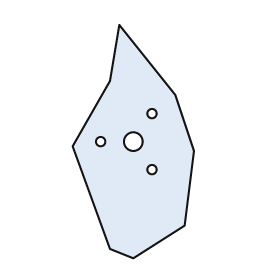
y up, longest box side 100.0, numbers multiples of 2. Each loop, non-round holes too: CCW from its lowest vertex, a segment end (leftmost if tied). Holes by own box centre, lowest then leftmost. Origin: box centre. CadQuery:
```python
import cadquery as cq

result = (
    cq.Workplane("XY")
    .moveTo(0.0, -50.0)
    .lineTo(22.0, -36.0)
    .lineTo(26.0, -4.0)
    .lineTo(18.0, 20.0)
    .lineTo(-6.0, 50.0)
    .lineTo(-10.0, 26.0)
    .lineTo(-26.0, -2.0)
    .lineTo(-10.0, -46.0)
    .close()
    .moveTo(8.0, -12.0)
    .circle(2.0)
    .moveTo(-14.0, 0.0)
    .circle(2.0)
    .moveTo(0.0, 0.0)
    .circle(4.0)
    .moveTo(8.0, 12.0)
    .circle(2.0)
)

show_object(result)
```